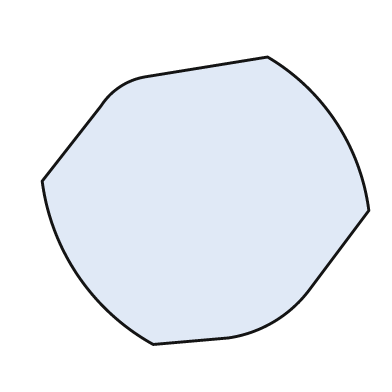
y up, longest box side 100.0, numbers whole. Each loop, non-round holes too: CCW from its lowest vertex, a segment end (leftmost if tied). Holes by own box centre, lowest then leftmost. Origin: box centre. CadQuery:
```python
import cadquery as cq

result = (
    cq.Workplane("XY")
    .moveTo(-16.0, -44.0)
    .lineTo(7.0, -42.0)
    .threePointArc((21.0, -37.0), (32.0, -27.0))
    .lineTo(50.0, -3.0)
    .threePointArc((40.0, 24.0), (19.0, 44.0))
    .lineTo(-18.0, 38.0)
    .threePointArc((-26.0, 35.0), (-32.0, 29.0))
    .lineTo(-50.0, 6.0)
    .threePointArc((-39.0, -23.0), (-16.0, -44.0))
    .close()
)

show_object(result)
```